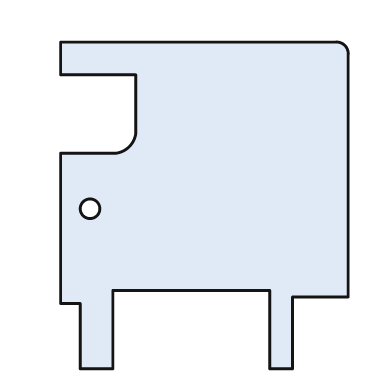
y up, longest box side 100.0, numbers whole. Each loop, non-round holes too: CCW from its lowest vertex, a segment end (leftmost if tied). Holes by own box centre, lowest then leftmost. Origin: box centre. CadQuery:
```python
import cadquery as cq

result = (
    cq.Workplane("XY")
    .moveTo(-38.0, -50.0)
    .lineTo(-28.0, -50.0)
    .lineTo(-28.0, -26.0)
    .lineTo(20.0, -26.0)
    .lineTo(20.0, -50.0)
    .lineTo(27.0, -50.0)
    .lineTo(27.0, -28.0)
    .lineTo(44.0, -28.0)
    .lineTo(44.0, 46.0)
    .threePointArc((43.0, 49.0), (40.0, 50.0))
    .lineTo(-44.0, 50.0)
    .lineTo(-44.0, 40.0)
    .lineTo(-21.0, 40.0)
    .lineTo(-21.0, 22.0)
    .threePointArc((-23.0, 18.0), (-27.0, 16.0))
    .lineTo(-44.0, 16.0)
    .lineTo(-44.0, -30.0)
    .lineTo(-38.0, -30.0)
    .close()
    .moveTo(-35.0, -1.0)
    .circle(3.0)
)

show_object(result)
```